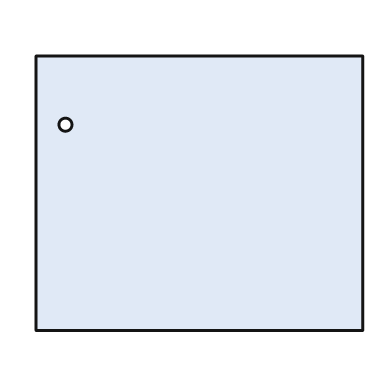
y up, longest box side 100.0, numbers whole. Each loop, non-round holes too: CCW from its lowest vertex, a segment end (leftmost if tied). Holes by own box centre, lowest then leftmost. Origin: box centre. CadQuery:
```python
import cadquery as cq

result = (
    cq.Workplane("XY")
    .moveTo(-50.0, -42.0)
    .lineTo(50.0, -42.0)
    .lineTo(50.0, 42.0)
    .lineTo(-50.0, 42.0)
    .close()
    .moveTo(-41.0, 21.0)
    .circle(2.0)
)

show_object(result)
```